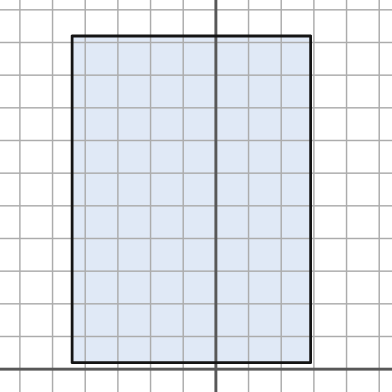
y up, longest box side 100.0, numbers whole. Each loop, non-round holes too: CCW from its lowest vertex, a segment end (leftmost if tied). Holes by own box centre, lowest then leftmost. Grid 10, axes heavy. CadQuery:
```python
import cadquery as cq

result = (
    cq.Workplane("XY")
    .moveTo(-44.0, 2.0)
    .lineTo(29.0, 2.0)
    .lineTo(29.0, 102.0)
    .lineTo(-44.0, 102.0)
    .close()
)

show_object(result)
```